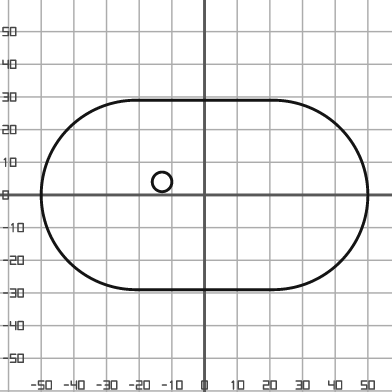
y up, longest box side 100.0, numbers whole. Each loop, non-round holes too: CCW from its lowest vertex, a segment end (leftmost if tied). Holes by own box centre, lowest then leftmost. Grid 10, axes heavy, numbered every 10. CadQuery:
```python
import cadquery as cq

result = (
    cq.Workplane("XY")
    .moveTo(-21.0, -29.0)
    .lineTo(21.0, -29.0)
    .threePointArc((50.0, 0.0), (21.0, 29.0))
    .lineTo(-21.0, 29.0)
    .threePointArc((-50.0, 0.0), (-21.0, -29.0))
    .close()
    .moveTo(-13.0, 4.0)
    .circle(3.0)
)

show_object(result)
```